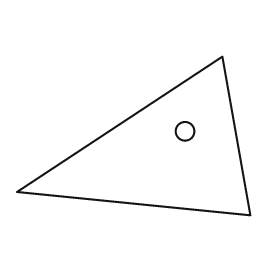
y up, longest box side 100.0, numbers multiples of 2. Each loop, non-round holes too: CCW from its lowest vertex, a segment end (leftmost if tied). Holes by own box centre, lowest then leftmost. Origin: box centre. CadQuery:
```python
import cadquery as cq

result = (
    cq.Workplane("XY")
    .moveTo(50.0, -34.0)
    .lineTo(38.0, 34.0)
    .lineTo(-50.0, -24.0)
    .close()
    .moveTo(22.0, 2.0)
    .circle(4.0)
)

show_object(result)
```